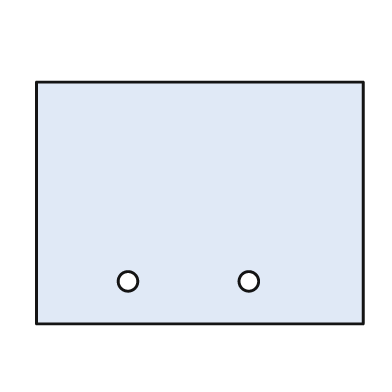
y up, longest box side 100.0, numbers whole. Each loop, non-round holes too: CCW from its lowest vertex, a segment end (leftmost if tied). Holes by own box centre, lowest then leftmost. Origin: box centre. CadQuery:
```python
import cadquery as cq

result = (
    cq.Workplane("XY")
    .moveTo(-50.0, -37.0)
    .lineTo(50.0, -37.0)
    .lineTo(50.0, 37.0)
    .lineTo(-50.0, 37.0)
    .close()
    .moveTo(-22.0, -24.0)
    .circle(3.0)
    .moveTo(15.0, -24.0)
    .circle(3.0)
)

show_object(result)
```